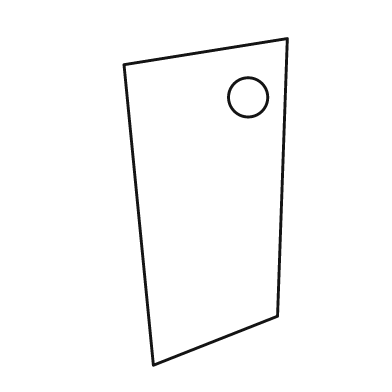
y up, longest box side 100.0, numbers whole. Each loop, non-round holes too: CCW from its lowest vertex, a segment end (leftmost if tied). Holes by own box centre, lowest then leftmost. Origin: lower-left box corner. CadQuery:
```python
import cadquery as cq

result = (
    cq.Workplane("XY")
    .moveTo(9.0, 0.0)
    .lineTo(47.0, 15.0)
    .lineTo(50.0, 100.0)
    .lineTo(0.0, 92.0)
    .close()
    .moveTo(38.0, 82.0)
    .circle(6.0)
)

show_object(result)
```